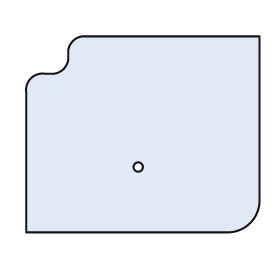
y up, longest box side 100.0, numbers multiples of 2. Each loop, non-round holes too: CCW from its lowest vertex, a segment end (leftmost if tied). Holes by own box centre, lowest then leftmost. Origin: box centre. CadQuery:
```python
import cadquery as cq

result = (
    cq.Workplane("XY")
    .moveTo(-50.0, -42.0)
    .lineTo(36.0, -42.0)
    .threePointArc((46.0, -38.0), (50.0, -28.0))
    .lineTo(50.0, 42.0)
    .lineTo(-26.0, 42.0)
    .threePointArc((-30.0, 40.0), (-32.0, 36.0))
    .lineTo(-32.0, 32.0)
    .threePointArc((-34.0, 28.0), (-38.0, 26.0))
    .lineTo(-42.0, 26.0)
    .threePointArc((-48.0, 24.0), (-50.0, 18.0))
    .close()
    .moveTo(-2.0, -14.0)
    .circle(2.0)
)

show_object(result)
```